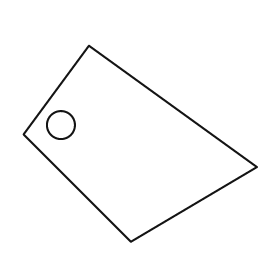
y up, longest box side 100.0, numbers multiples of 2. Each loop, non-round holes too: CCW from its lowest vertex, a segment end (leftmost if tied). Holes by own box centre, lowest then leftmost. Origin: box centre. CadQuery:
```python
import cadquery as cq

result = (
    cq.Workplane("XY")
    .moveTo(-4.0, -42.0)
    .lineTo(50.0, -10.0)
    .lineTo(-22.0, 42.0)
    .lineTo(-50.0, 4.0)
    .close()
    .moveTo(-34.0, 8.0)
    .circle(6.0)
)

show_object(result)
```